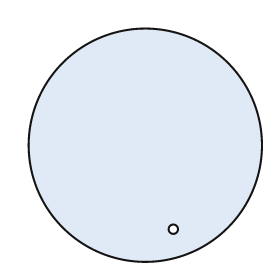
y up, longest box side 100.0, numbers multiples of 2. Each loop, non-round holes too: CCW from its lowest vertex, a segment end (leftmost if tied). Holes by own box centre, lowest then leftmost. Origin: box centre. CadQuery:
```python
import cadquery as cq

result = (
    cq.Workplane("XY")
    .moveTo(0.0, 0.0)
    .circle(50.0)
    .moveTo(12.0, -36.0)
    .circle(2.0)
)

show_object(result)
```